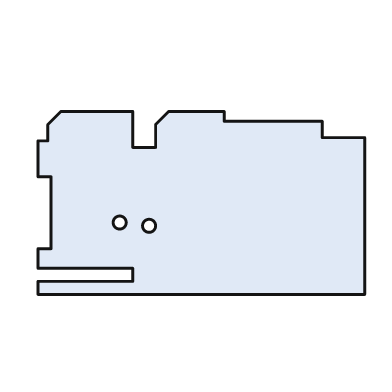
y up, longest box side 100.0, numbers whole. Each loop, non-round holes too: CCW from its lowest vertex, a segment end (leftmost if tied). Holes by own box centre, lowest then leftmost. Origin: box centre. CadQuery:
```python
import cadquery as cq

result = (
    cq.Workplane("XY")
    .moveTo(-50.0, -28.0)
    .lineTo(50.0, -28.0)
    .lineTo(50.0, 20.0)
    .lineTo(37.0, 20.0)
    .lineTo(37.0, 25.0)
    .lineTo(7.0, 25.0)
    .lineTo(7.0, 28.0)
    .lineTo(-10.0, 28.0)
    .lineTo(-14.0, 24.0)
    .lineTo(-14.0, 17.0)
    .lineTo(-21.0, 17.0)
    .lineTo(-21.0, 28.0)
    .lineTo(-43.0, 28.0)
    .lineTo(-47.0, 24.0)
    .lineTo(-47.0, 19.0)
    .lineTo(-50.0, 19.0)
    .lineTo(-50.0, 8.0)
    .lineTo(-46.0, 8.0)
    .lineTo(-46.0, -14.0)
    .lineTo(-50.0, -14.0)
    .lineTo(-50.0, -20.0)
    .lineTo(-21.0, -20.0)
    .lineTo(-21.0, -24.0)
    .lineTo(-50.0, -24.0)
    .close()
    .moveTo(-16.0, -7.0)
    .circle(2.0)
    .moveTo(-25.0, -6.0)
    .circle(2.0)
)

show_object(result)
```